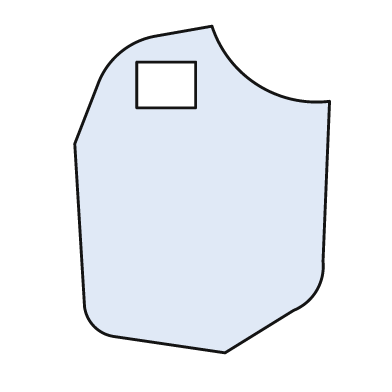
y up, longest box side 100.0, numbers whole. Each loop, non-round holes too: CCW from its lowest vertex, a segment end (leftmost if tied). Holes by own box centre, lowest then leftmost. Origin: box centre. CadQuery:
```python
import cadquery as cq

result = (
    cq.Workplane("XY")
    .moveTo(7.0, -50.0)
    .lineTo(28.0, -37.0)
    .threePointArc((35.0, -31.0), (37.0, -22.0))
    .lineTo(39.0, 27.0)
    .threePointArc((17.0, 32.0), (3.0, 50.0))
    .lineTo(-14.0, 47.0)
    .threePointArc((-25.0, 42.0), (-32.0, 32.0))
    .lineTo(-39.0, 14.0)
    .lineTo(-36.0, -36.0)
    .threePointArc((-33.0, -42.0), (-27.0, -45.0))
    .close()
    .moveTo(-20.0, 25.0)
    .lineTo(-2.0, 25.0)
    .lineTo(-2.0, 39.0)
    .lineTo(-20.0, 39.0)
    .close()
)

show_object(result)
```